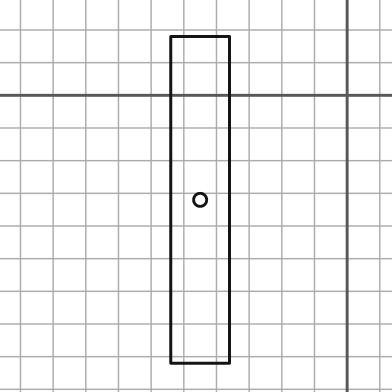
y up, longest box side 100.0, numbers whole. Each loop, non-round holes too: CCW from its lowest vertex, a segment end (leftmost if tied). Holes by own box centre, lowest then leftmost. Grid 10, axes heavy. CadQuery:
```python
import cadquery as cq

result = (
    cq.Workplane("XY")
    .moveTo(-54.0, -82.0)
    .lineTo(-36.0, -82.0)
    .lineTo(-36.0, 18.0)
    .lineTo(-54.0, 18.0)
    .close()
    .moveTo(-45.0, -32.0)
    .circle(2.0)
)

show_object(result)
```